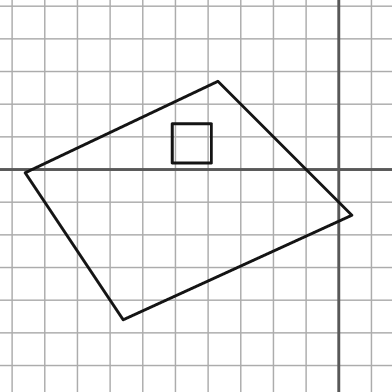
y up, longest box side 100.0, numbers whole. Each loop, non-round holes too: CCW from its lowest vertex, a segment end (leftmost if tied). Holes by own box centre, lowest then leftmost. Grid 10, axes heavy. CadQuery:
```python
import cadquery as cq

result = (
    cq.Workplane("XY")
    .moveTo(-66.0, -46.0)
    .lineTo(4.0, -14.0)
    .lineTo(-37.0, 27.0)
    .lineTo(-96.0, -1.0)
    .close()
    .moveTo(-51.0, 2.0)
    .lineTo(-39.0, 2.0)
    .lineTo(-39.0, 14.0)
    .lineTo(-51.0, 14.0)
    .close()
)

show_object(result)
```